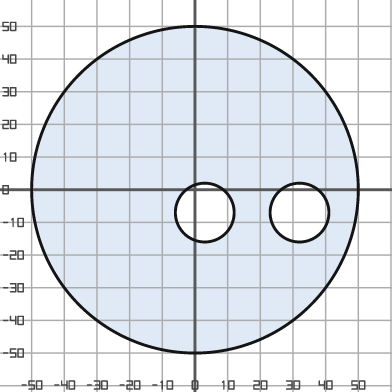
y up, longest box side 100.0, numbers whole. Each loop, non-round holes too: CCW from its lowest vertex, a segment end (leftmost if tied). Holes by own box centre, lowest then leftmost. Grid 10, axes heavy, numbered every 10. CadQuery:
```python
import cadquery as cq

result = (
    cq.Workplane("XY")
    .moveTo(0.0, 0.0)
    .circle(50.0)
    .moveTo(3.0, -7.0)
    .circle(9.0)
    .moveTo(32.0, -7.0)
    .circle(9.0)
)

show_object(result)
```